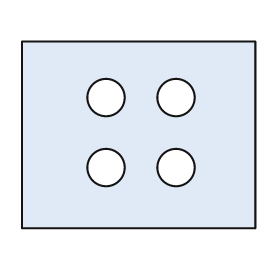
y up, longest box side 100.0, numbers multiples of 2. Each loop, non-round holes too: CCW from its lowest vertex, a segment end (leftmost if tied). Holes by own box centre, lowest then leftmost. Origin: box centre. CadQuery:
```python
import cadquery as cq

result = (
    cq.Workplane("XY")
    .moveTo(-50.0, -40.0)
    .lineTo(50.0, -40.0)
    .lineTo(50.0, 40.0)
    .lineTo(-50.0, 40.0)
    .close()
    .moveTo(-14.0, -14.0)
    .circle(8.0)
    .moveTo(16.0, -14.0)
    .circle(8.0)
    .moveTo(-14.0, 16.0)
    .circle(8.0)
    .moveTo(16.0, 16.0)
    .circle(8.0)
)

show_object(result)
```